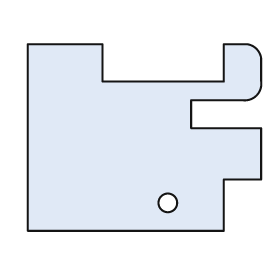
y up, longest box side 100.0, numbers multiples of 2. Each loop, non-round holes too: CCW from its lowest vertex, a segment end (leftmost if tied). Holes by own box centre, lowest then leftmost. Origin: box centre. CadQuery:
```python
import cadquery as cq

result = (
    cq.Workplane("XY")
    .moveTo(-50.0, -40.0)
    .lineTo(34.0, -40.0)
    .lineTo(34.0, -18.0)
    .lineTo(50.0, -18.0)
    .lineTo(50.0, 4.0)
    .lineTo(20.0, 4.0)
    .lineTo(20.0, 16.0)
    .lineTo(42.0, 16.0)
    .threePointArc((48.0, 18.0), (50.0, 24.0))
    .lineTo(50.0, 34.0)
    .threePointArc((48.0, 38.0), (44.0, 40.0))
    .lineTo(34.0, 40.0)
    .lineTo(34.0, 24.0)
    .lineTo(-18.0, 24.0)
    .lineTo(-18.0, 40.0)
    .lineTo(-50.0, 40.0)
    .close()
    .moveTo(10.0, -28.0)
    .circle(4.0)
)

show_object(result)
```